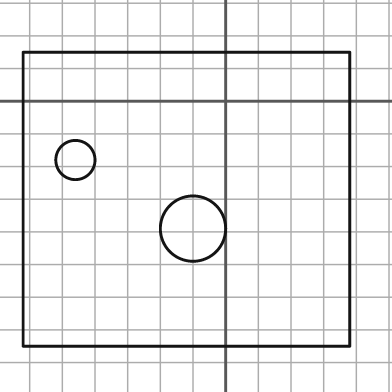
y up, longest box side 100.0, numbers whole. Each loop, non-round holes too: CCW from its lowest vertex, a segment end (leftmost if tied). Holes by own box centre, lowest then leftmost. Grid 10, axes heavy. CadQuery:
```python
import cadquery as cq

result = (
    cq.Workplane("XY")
    .moveTo(-62.0, -75.0)
    .lineTo(38.0, -75.0)
    .lineTo(38.0, 15.0)
    .lineTo(-62.0, 15.0)
    .close()
    .moveTo(-10.0, -39.0)
    .circle(10.0)
    .moveTo(-46.0, -18.0)
    .circle(6.0)
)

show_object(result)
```